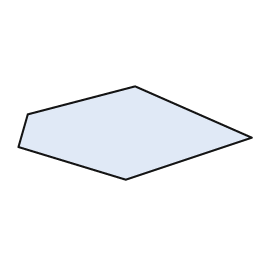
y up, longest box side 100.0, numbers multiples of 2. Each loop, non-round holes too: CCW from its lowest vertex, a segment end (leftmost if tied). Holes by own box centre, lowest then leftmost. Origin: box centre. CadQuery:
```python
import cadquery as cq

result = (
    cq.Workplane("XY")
    .moveTo(-4.0, -20.0)
    .lineTo(50.0, -2.0)
    .lineTo(0.0, 20.0)
    .lineTo(-46.0, 8.0)
    .lineTo(-50.0, -6.0)
    .close()
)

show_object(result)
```